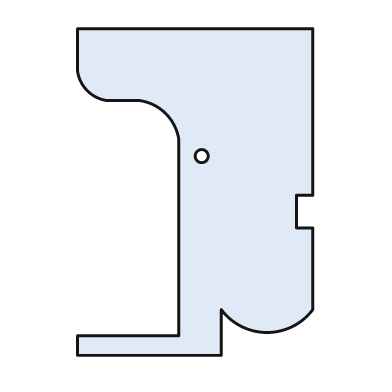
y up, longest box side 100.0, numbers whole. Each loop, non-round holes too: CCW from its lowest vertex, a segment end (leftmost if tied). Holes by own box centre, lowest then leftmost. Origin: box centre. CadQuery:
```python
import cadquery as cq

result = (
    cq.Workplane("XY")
    .moveTo(-36.0, -50.0)
    .lineTo(8.0, -50.0)
    .lineTo(8.0, -36.0)
    .threePointArc((22.0, -43.0), (36.0, -36.0))
    .lineTo(36.0, -11.0)
    .lineTo(31.0, -11.0)
    .lineTo(31.0, -1.0)
    .lineTo(36.0, -1.0)
    .lineTo(36.0, 50.0)
    .lineTo(-36.0, 50.0)
    .lineTo(-36.0, 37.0)
    .threePointArc((-33.0, 31.0), (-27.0, 28.0))
    .lineTo(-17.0, 28.0)
    .threePointArc((-9.0, 24.0), (-5.0, 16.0))
    .lineTo(-5.0, -44.0)
    .lineTo(-36.0, -44.0)
    .close()
    .moveTo(2.0, 11.0)
    .circle(2.0)
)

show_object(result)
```